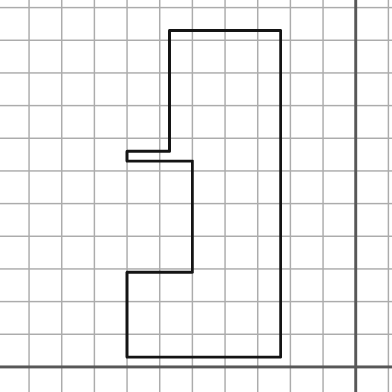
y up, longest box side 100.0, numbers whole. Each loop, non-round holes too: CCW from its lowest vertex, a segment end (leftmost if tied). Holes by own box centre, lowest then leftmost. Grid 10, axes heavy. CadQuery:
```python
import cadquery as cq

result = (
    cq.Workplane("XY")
    .moveTo(-70.0, 3.0)
    .lineTo(-23.0, 3.0)
    .lineTo(-23.0, 103.0)
    .lineTo(-57.0, 103.0)
    .lineTo(-57.0, 66.0)
    .lineTo(-70.0, 66.0)
    .lineTo(-70.0, 63.0)
    .lineTo(-50.0, 63.0)
    .lineTo(-50.0, 29.0)
    .lineTo(-70.0, 29.0)
    .close()
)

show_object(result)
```